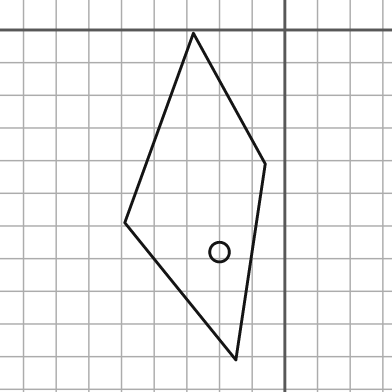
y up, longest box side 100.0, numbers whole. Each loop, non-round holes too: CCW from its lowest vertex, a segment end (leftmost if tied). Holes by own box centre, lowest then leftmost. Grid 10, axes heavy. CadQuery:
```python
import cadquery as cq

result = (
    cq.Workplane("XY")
    .moveTo(-15.0, -101.0)
    .lineTo(-6.0, -41.0)
    .lineTo(-28.0, -1.0)
    .lineTo(-49.0, -59.0)
    .close()
    .moveTo(-20.0, -68.0)
    .circle(3.0)
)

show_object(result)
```